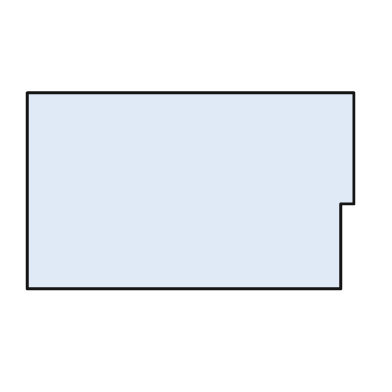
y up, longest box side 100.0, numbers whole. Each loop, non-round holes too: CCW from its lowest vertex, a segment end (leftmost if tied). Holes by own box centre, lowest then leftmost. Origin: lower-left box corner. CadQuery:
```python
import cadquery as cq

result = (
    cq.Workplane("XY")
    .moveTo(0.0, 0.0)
    .lineTo(96.0, 0.0)
    .lineTo(96.0, 26.0)
    .lineTo(100.0, 26.0)
    .lineTo(100.0, 60.0)
    .lineTo(0.0, 60.0)
    .close()
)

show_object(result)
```